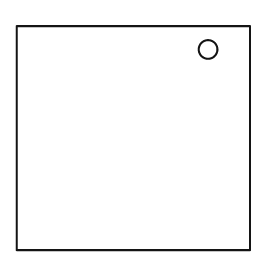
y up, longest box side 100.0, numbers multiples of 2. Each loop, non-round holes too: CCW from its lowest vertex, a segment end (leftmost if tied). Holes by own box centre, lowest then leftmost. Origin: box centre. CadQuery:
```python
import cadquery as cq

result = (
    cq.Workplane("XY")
    .moveTo(-50.0, -48.0)
    .lineTo(50.0, -48.0)
    .lineTo(50.0, 48.0)
    .lineTo(-50.0, 48.0)
    .close()
    .moveTo(32.0, 38.0)
    .circle(4.0)
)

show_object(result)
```